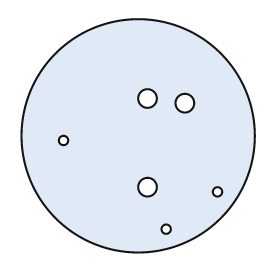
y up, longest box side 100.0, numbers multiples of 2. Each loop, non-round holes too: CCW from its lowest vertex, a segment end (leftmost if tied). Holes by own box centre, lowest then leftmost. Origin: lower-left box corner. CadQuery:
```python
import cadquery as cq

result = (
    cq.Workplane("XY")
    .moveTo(50.0, 50.0)
    .circle(50.0)
    .moveTo(62.0, 10.0)
    .circle(2.0)
    .moveTo(84.0, 26.0)
    .circle(2.0)
    .moveTo(54.0, 28.0)
    .circle(4.0)
    .moveTo(18.0, 48.0)
    .circle(2.0)
    .moveTo(70.0, 64.0)
    .circle(4.0)
    .moveTo(54.0, 66.0)
    .circle(4.0)
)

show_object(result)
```